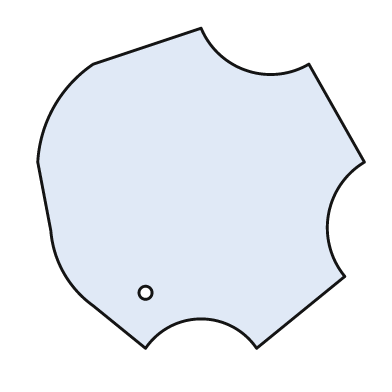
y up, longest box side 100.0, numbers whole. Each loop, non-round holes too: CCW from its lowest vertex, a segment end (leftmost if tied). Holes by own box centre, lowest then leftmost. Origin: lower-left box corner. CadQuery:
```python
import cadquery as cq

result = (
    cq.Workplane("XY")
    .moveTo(33.0, 0.0)
    .threePointArc((50.0, 9.0), (67.0, 0.0))
    .lineTo(94.0, 22.0)
    .threePointArc((89.0, 41.0), (100.0, 57.0))
    .lineTo(83.0, 87.0)
    .threePointArc((64.0, 85.0), (50.0, 98.0))
    .lineTo(17.0, 87.0)
    .threePointArc((5.0, 74.0), (0.0, 57.0))
    .lineTo(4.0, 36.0)
    .threePointArc((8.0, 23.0), (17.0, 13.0))
    .close()
    .moveTo(33.0, 17.0)
    .circle(2.0)
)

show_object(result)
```